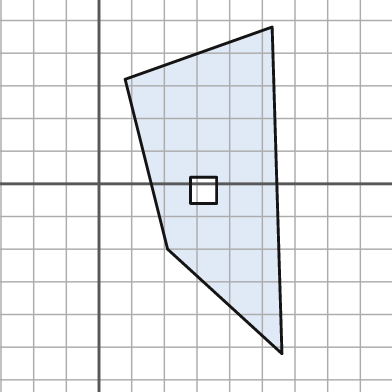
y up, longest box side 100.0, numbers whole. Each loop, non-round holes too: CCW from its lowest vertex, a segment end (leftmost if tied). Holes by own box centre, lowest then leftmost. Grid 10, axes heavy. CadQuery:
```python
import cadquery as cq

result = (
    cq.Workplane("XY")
    .moveTo(56.0, -52.0)
    .lineTo(53.0, 48.0)
    .lineTo(8.0, 32.0)
    .lineTo(21.0, -20.0)
    .close()
    .moveTo(28.0, -6.0)
    .lineTo(36.0, -6.0)
    .lineTo(36.0, 2.0)
    .lineTo(28.0, 2.0)
    .close()
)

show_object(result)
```